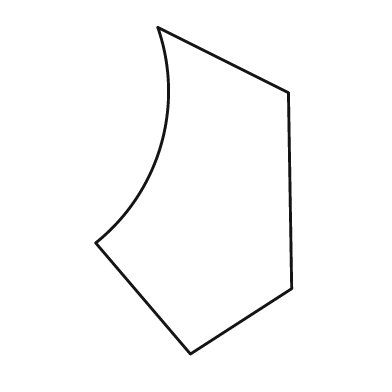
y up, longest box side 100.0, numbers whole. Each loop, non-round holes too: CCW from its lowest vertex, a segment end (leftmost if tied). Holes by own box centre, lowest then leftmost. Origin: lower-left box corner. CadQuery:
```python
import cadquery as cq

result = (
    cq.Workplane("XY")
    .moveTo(29.0, 0.0)
    .lineTo(60.0, 20.0)
    .lineTo(59.0, 80.0)
    .lineTo(19.0, 100.0)
    .threePointArc((20.0, 64.0), (0.0, 34.0))
    .close()
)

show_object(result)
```